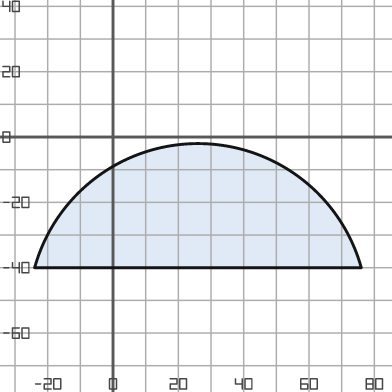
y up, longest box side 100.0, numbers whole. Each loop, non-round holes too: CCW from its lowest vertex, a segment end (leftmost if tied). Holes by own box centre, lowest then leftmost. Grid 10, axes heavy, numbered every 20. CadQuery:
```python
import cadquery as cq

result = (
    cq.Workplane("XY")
    .moveTo(-24.0, -40.0)
    .lineTo(76.0, -40.0)
    .threePointArc((26.0, -2.0), (-24.0, -40.0))
    .close()
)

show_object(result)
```